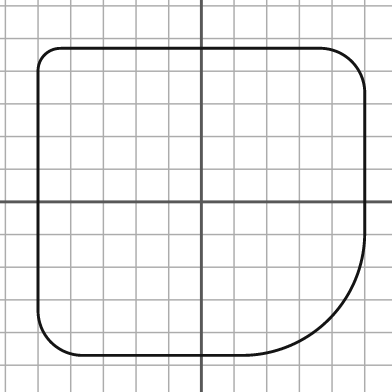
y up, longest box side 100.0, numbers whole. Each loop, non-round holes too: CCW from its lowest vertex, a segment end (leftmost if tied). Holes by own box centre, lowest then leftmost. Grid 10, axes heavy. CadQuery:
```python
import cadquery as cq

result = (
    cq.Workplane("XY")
    .moveTo(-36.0, -47.0)
    .lineTo(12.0, -47.0)
    .threePointArc((39.0, -36.0), (50.0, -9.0))
    .lineTo(50.0, 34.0)
    .threePointArc((46.0, 43.0), (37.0, 47.0))
    .lineTo(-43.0, 47.0)
    .threePointArc((-48.0, 45.0), (-50.0, 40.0))
    .lineTo(-50.0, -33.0)
    .threePointArc((-46.0, -43.0), (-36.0, -47.0))
    .close()
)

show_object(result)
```